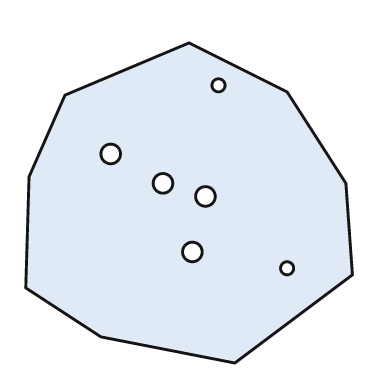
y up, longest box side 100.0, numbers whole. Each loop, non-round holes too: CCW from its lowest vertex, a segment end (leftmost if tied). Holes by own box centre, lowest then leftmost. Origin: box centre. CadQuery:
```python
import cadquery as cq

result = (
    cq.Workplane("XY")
    .moveTo(14.0, -49.0)
    .lineTo(50.0, -22.0)
    .lineTo(48.0, 6.0)
    .lineTo(30.0, 34.0)
    .lineTo(0.0, 49.0)
    .lineTo(-38.0, 33.0)
    .lineTo(-49.0, 8.0)
    .lineTo(-50.0, -26.0)
    .lineTo(-27.0, -41.0)
    .close()
    .moveTo(30.0, -20.0)
    .circle(2.0)
    .moveTo(1.0, -15.0)
    .circle(3.0)
    .moveTo(5.0, 2.0)
    .circle(3.0)
    .moveTo(-8.0, 6.0)
    .circle(3.0)
    .moveTo(-24.0, 15.0)
    .circle(3.0)
    .moveTo(9.0, 36.0)
    .circle(2.0)
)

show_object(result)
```